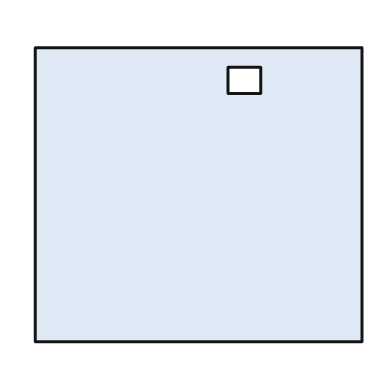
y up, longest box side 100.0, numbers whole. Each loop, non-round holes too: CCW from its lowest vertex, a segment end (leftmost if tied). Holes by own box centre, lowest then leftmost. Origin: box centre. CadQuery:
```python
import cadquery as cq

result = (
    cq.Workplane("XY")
    .moveTo(-50.0, -45.0)
    .lineTo(50.0, -45.0)
    .lineTo(50.0, 45.0)
    .lineTo(-50.0, 45.0)
    .close()
    .moveTo(9.0, 31.0)
    .lineTo(19.0, 31.0)
    .lineTo(19.0, 39.0)
    .lineTo(9.0, 39.0)
    .close()
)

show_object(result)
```